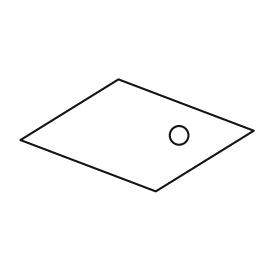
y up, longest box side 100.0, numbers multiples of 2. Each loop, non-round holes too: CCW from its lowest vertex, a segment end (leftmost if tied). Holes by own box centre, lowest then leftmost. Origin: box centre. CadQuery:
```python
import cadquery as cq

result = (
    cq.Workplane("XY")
    .moveTo(8.0, -24.0)
    .lineTo(50.0, 2.0)
    .lineTo(-8.0, 24.0)
    .lineTo(-50.0, -2.0)
    .close()
    .moveTo(18.0, 0.0)
    .circle(4.0)
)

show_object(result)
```